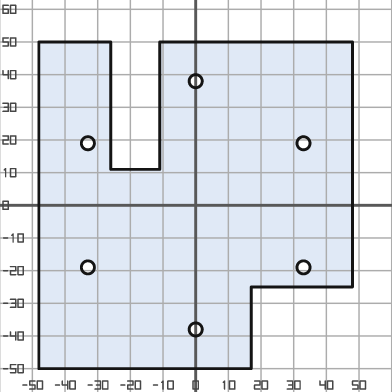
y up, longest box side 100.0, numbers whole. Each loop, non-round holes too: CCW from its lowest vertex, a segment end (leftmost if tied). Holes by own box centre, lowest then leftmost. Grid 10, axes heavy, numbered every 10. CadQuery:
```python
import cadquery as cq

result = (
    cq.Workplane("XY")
    .moveTo(-48.0, -50.0)
    .lineTo(17.0, -50.0)
    .lineTo(17.0, -25.0)
    .lineTo(48.0, -25.0)
    .lineTo(48.0, 50.0)
    .lineTo(-11.0, 50.0)
    .lineTo(-11.0, 11.0)
    .lineTo(-26.0, 11.0)
    .lineTo(-26.0, 50.0)
    .lineTo(-48.0, 50.0)
    .close()
    .moveTo(0.0, -38.0)
    .circle(2.0)
    .moveTo(-33.0, -19.0)
    .circle(2.0)
    .moveTo(33.0, -19.0)
    .circle(2.0)
    .moveTo(-33.0, 19.0)
    .circle(2.0)
    .moveTo(33.0, 19.0)
    .circle(2.0)
    .moveTo(0.0, 38.0)
    .circle(2.0)
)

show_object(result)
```